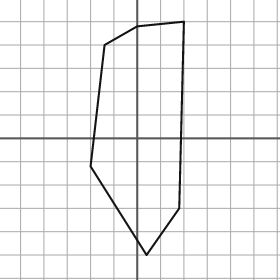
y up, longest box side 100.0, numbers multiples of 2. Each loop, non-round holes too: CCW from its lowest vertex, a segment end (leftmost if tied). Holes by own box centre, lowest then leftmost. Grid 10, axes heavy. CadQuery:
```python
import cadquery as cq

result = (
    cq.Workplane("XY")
    .moveTo(4.0, -50.0)
    .lineTo(18.0, -30.0)
    .lineTo(20.0, 50.0)
    .lineTo(0.0, 48.0)
    .lineTo(-14.0, 40.0)
    .lineTo(-20.0, -12.0)
    .close()
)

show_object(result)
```